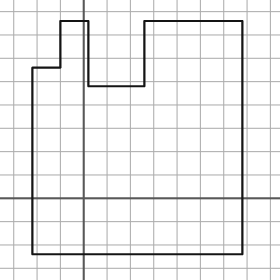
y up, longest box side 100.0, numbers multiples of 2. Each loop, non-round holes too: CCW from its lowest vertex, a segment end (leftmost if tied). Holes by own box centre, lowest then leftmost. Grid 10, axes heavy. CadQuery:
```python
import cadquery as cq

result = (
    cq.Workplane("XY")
    .moveTo(-22.0, -24.0)
    .lineTo(68.0, -24.0)
    .lineTo(68.0, 76.0)
    .lineTo(26.0, 76.0)
    .lineTo(26.0, 48.0)
    .lineTo(2.0, 48.0)
    .lineTo(2.0, 76.0)
    .lineTo(-10.0, 76.0)
    .lineTo(-10.0, 56.0)
    .lineTo(-22.0, 56.0)
    .close()
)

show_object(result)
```